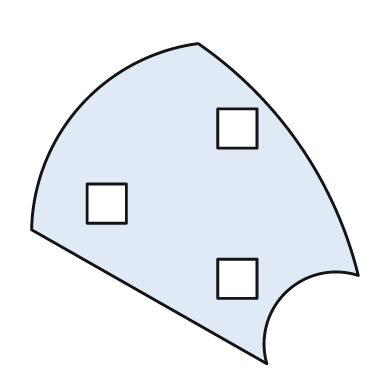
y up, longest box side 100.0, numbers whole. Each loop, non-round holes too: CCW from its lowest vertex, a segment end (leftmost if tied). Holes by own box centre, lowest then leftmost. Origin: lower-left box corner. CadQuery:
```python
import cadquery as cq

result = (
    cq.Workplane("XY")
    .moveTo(72.0, 0.0)
    .threePointArc((78.0, 22.0), (100.0, 27.0))
    .threePointArc((82.0, 67.0), (51.0, 98.0))
    .threePointArc((15.0, 79.0), (0.0, 41.0))
    .close()
    .moveTo(57.0, 20.0)
    .lineTo(69.0, 20.0)
    .lineTo(69.0, 32.0)
    .lineTo(57.0, 32.0)
    .close()
    .moveTo(17.0, 43.0)
    .lineTo(29.0, 43.0)
    .lineTo(29.0, 55.0)
    .lineTo(17.0, 55.0)
    .close()
    .moveTo(57.0, 66.0)
    .lineTo(69.0, 66.0)
    .lineTo(69.0, 78.0)
    .lineTo(57.0, 78.0)
    .close()
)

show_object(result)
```